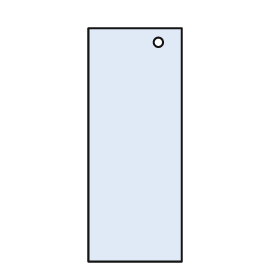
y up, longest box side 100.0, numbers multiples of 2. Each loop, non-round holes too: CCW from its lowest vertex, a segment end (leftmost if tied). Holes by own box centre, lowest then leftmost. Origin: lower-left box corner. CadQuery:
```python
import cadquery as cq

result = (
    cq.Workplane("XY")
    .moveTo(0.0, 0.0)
    .lineTo(40.0, 0.0)
    .lineTo(40.0, 100.0)
    .lineTo(0.0, 100.0)
    .close()
    .moveTo(30.0, 94.0)
    .circle(2.0)
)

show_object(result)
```